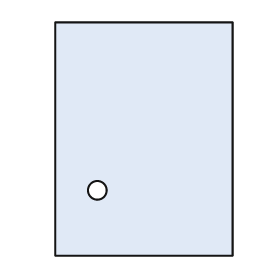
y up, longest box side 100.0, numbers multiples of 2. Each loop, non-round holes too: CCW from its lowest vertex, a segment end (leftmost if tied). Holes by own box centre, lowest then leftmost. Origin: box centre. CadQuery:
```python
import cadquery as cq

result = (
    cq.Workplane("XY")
    .moveTo(-38.0, -50.0)
    .lineTo(38.0, -50.0)
    .lineTo(38.0, 50.0)
    .lineTo(-38.0, 50.0)
    .close()
    .moveTo(-20.0, -22.0)
    .circle(4.0)
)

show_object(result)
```